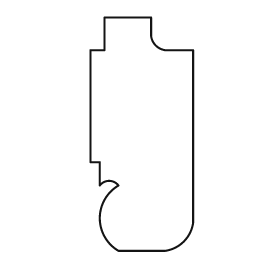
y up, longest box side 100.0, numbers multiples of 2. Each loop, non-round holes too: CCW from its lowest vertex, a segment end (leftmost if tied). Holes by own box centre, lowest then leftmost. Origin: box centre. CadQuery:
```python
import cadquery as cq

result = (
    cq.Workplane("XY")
    .moveTo(-10.0, -50.0)
    .lineTo(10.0, -50.0)
    .threePointArc((18.0, -46.0), (22.0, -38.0))
    .lineTo(22.0, 36.0)
    .lineTo(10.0, 36.0)
    .threePointArc((6.0, 38.0), (4.0, 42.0))
    .lineTo(4.0, 50.0)
    .lineTo(-16.0, 50.0)
    .lineTo(-16.0, 36.0)
    .lineTo(-22.0, 36.0)
    .lineTo(-22.0, -12.0)
    .lineTo(-18.0, -12.0)
    .lineTo(-18.0, -22.0)
    .threePointArc((-14.0, -20.0), (-10.0, -22.0))
    .threePointArc((-18.0, -36.0), (-10.0, -50.0))
    .close()
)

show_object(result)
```